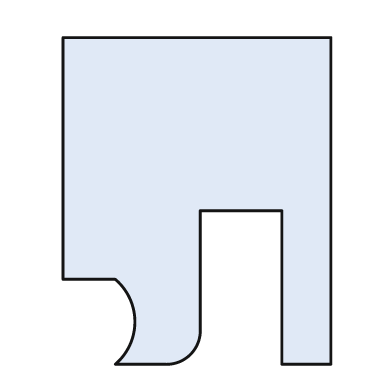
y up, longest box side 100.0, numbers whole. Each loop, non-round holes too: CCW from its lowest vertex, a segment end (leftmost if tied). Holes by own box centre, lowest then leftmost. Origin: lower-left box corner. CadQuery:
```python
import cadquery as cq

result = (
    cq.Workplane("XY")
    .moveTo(16.0, 0.0)
    .lineTo(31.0, 0.0)
    .threePointArc((39.0, 3.0), (42.0, 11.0))
    .lineTo(42.0, 47.0)
    .lineTo(67.0, 47.0)
    .lineTo(67.0, 0.0)
    .lineTo(82.0, 0.0)
    .lineTo(82.0, 100.0)
    .lineTo(0.0, 100.0)
    .lineTo(0.0, 26.0)
    .lineTo(16.0, 26.0)
    .threePointArc((22.0, 13.0), (16.0, 0.0))
    .close()
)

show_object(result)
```